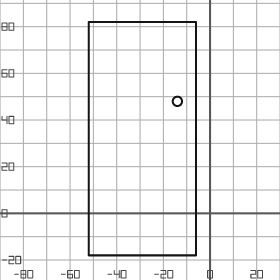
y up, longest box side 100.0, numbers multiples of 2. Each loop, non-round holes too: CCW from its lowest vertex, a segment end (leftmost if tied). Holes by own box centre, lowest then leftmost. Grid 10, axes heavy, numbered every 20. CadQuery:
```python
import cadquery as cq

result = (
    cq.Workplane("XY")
    .moveTo(-52.0, -18.0)
    .lineTo(-6.0, -18.0)
    .lineTo(-6.0, 82.0)
    .lineTo(-52.0, 82.0)
    .close()
    .moveTo(-14.0, 48.0)
    .circle(2.0)
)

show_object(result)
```